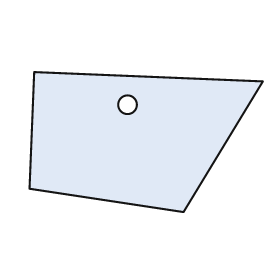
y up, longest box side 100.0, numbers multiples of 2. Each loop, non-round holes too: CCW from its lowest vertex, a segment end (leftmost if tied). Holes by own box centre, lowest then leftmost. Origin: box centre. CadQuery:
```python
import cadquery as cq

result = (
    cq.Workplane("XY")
    .moveTo(16.0, -30.0)
    .lineTo(50.0, 26.0)
    .lineTo(-48.0, 30.0)
    .lineTo(-50.0, -20.0)
    .close()
    .moveTo(-8.0, 16.0)
    .circle(4.0)
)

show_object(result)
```